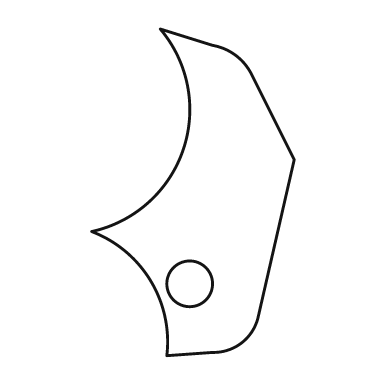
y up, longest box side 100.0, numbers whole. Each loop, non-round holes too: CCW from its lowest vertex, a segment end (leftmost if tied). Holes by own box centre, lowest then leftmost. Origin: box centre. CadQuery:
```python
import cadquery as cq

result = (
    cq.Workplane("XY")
    .moveTo(-8.0, -50.0)
    .lineTo(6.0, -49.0)
    .threePointArc((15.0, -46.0), (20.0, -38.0))
    .lineTo(31.0, 10.0)
    .lineTo(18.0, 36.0)
    .threePointArc((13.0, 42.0), (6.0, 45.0))
    .lineTo(-10.0, 50.0)
    .threePointArc((-3.0, 13.0), (-31.0, -12.0))
    .threePointArc((-13.0, -27.0), (-8.0, -50.0))
    .close()
    .moveTo(-1.0, -28.0)
    .circle(7.0)
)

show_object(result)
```